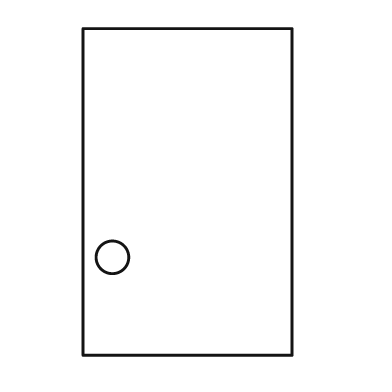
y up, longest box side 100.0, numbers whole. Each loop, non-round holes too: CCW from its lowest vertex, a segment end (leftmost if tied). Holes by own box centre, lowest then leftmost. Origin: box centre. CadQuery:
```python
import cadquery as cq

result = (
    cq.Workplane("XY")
    .moveTo(-32.0, -50.0)
    .lineTo(32.0, -50.0)
    .lineTo(32.0, 50.0)
    .lineTo(-32.0, 50.0)
    .close()
    .moveTo(-23.0, -20.0)
    .circle(5.0)
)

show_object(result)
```